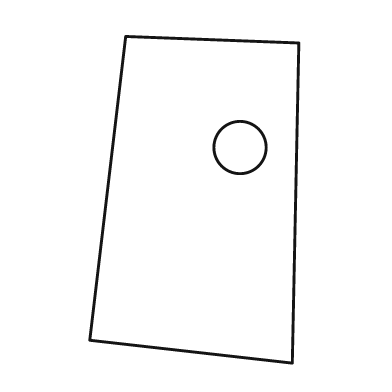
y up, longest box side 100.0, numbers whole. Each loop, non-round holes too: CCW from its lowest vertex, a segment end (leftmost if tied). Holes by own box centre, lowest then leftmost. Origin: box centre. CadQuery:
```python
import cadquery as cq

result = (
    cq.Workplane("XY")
    .moveTo(30.0, -50.0)
    .lineTo(32.0, 48.0)
    .lineTo(-21.0, 50.0)
    .lineTo(-32.0, -43.0)
    .close()
    .moveTo(14.0, 16.0)
    .circle(8.0)
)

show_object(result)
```